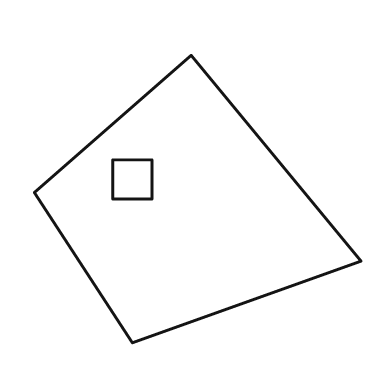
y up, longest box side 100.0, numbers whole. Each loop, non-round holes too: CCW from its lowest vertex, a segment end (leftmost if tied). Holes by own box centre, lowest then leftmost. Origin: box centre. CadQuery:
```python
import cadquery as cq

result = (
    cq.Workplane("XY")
    .moveTo(-20.0, -44.0)
    .lineTo(50.0, -19.0)
    .lineTo(-2.0, 44.0)
    .lineTo(-50.0, 2.0)
    .close()
    .moveTo(-26.0, 0.0)
    .lineTo(-14.0, 0.0)
    .lineTo(-14.0, 12.0)
    .lineTo(-26.0, 12.0)
    .close()
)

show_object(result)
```